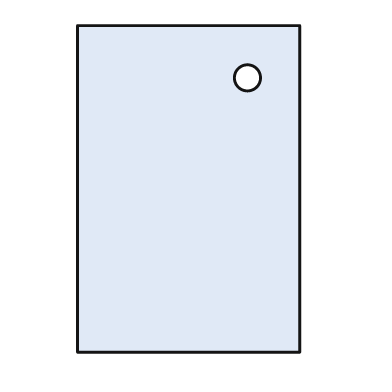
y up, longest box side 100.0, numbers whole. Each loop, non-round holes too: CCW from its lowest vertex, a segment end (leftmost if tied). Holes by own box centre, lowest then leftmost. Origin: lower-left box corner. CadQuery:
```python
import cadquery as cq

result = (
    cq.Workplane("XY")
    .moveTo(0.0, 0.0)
    .lineTo(68.0, 0.0)
    .lineTo(68.0, 100.0)
    .lineTo(0.0, 100.0)
    .close()
    .moveTo(52.0, 84.0)
    .circle(4.0)
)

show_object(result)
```